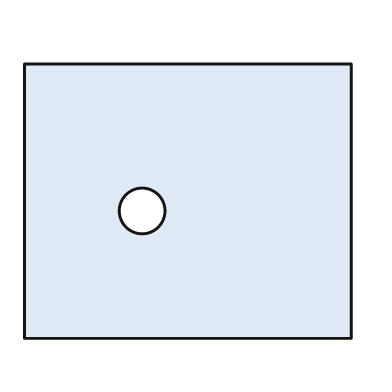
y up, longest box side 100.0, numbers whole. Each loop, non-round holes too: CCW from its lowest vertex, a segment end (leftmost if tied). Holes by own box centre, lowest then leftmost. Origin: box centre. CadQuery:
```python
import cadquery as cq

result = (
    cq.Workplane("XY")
    .moveTo(-50.0, -42.0)
    .lineTo(50.0, -42.0)
    .lineTo(50.0, 42.0)
    .lineTo(-50.0, 42.0)
    .close()
    .moveTo(-14.0, -3.0)
    .circle(7.0)
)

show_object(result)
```